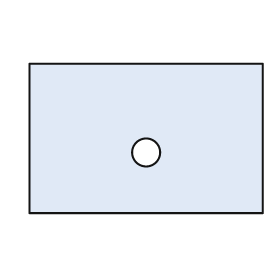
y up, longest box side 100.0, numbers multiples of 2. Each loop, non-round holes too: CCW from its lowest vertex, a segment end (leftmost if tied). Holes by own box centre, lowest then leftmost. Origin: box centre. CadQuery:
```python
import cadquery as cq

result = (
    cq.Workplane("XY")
    .moveTo(-50.0, -32.0)
    .lineTo(50.0, -32.0)
    .lineTo(50.0, 32.0)
    .lineTo(-50.0, 32.0)
    .close()
    .moveTo(0.0, -6.0)
    .circle(6.0)
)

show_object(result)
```